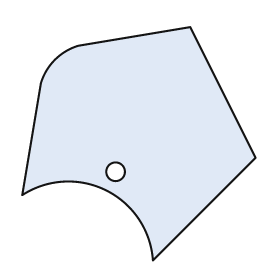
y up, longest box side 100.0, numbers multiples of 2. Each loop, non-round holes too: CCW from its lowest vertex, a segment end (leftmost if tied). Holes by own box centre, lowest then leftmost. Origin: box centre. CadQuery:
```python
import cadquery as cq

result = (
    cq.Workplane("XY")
    .moveTo(6.0, -50.0)
    .lineTo(50.0, -6.0)
    .lineTo(22.0, 50.0)
    .lineTo(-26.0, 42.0)
    .threePointArc((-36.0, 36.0), (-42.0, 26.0))
    .lineTo(-50.0, -22.0)
    .threePointArc((-14.0, -20.0), (6.0, -50.0))
    .close()
    .moveTo(-10.0, -12.0)
    .circle(4.0)
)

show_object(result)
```